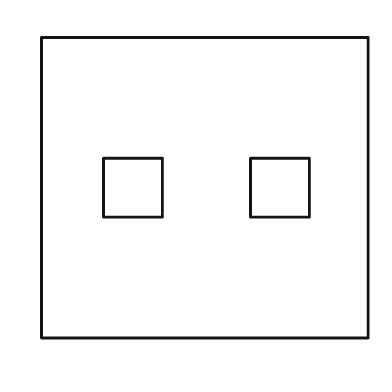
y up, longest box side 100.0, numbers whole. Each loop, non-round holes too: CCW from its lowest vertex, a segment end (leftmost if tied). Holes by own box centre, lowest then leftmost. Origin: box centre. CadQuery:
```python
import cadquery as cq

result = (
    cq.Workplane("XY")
    .moveTo(-50.0, -46.0)
    .lineTo(50.0, -46.0)
    .lineTo(50.0, 46.0)
    .lineTo(-50.0, 46.0)
    .close()
    .moveTo(-31.0, -9.0)
    .lineTo(-13.0, -9.0)
    .lineTo(-13.0, 9.0)
    .lineTo(-31.0, 9.0)
    .close()
    .moveTo(14.0, -9.0)
    .lineTo(32.0, -9.0)
    .lineTo(32.0, 9.0)
    .lineTo(14.0, 9.0)
    .close()
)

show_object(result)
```